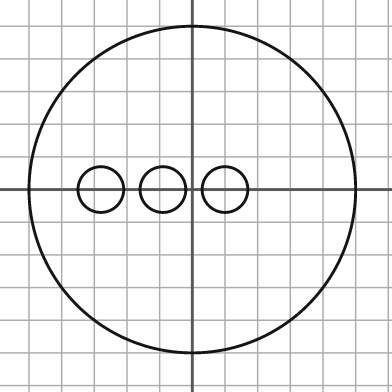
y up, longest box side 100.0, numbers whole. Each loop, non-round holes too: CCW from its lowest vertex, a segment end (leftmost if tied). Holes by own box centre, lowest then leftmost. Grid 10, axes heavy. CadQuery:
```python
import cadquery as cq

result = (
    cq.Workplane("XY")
    .moveTo(0.0, 0.0)
    .circle(50.0)
    .moveTo(-28.0, 0.0)
    .circle(7.0)
    .moveTo(-9.0, 0.0)
    .circle(7.0)
    .moveTo(10.0, 0.0)
    .circle(7.0)
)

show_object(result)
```